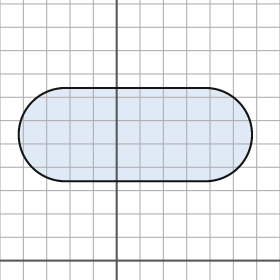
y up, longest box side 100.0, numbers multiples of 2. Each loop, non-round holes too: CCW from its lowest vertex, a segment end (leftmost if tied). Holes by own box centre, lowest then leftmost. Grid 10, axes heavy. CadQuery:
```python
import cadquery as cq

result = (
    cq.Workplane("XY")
    .moveTo(-22.0, 34.0)
    .lineTo(38.0, 34.0)
    .threePointArc((58.0, 54.0), (38.0, 74.0))
    .lineTo(-22.0, 74.0)
    .threePointArc((-42.0, 54.0), (-22.0, 34.0))
    .close()
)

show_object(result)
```